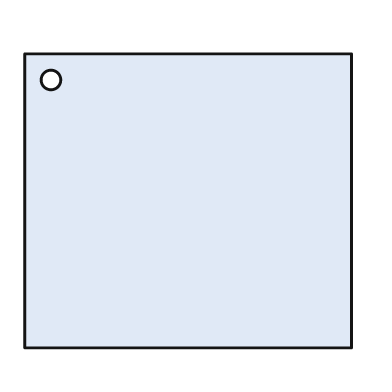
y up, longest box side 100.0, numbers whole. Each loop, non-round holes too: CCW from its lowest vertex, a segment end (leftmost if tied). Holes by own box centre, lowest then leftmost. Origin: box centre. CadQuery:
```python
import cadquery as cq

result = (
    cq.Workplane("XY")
    .moveTo(-50.0, -45.0)
    .lineTo(50.0, -45.0)
    .lineTo(50.0, 45.0)
    .lineTo(-50.0, 45.0)
    .close()
    .moveTo(-42.0, 37.0)
    .circle(3.0)
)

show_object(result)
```